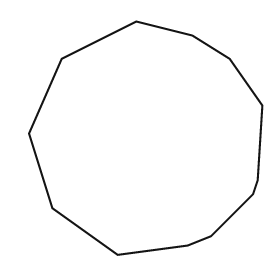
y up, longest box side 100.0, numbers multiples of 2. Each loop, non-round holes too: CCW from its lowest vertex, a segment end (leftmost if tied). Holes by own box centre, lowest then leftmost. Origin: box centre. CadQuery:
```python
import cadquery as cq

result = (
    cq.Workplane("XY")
    .moveTo(-12.0, -50.0)
    .lineTo(18.0, -46.0)
    .lineTo(28.0, -42.0)
    .lineTo(46.0, -24.0)
    .lineTo(48.0, -18.0)
    .lineTo(50.0, 14.0)
    .lineTo(36.0, 34.0)
    .lineTo(20.0, 44.0)
    .lineTo(-4.0, 50.0)
    .lineTo(-36.0, 34.0)
    .lineTo(-50.0, 2.0)
    .lineTo(-40.0, -30.0)
    .close()
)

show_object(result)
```